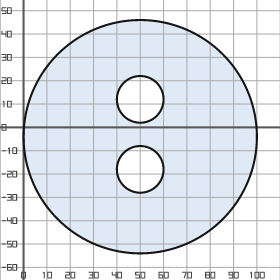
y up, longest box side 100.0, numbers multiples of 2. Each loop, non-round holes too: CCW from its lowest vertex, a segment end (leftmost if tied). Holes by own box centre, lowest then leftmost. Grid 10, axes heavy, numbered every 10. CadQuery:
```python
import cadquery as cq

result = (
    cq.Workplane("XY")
    .moveTo(50.0, -4.0)
    .circle(50.0)
    .moveTo(50.0, -18.0)
    .circle(10.0)
    .moveTo(50.0, 12.0)
    .circle(10.0)
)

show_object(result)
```